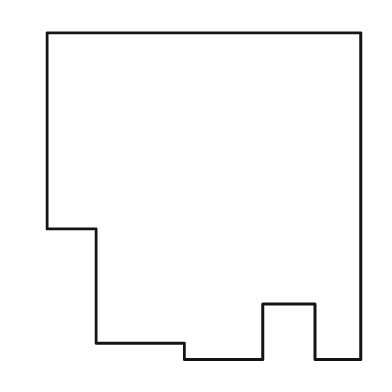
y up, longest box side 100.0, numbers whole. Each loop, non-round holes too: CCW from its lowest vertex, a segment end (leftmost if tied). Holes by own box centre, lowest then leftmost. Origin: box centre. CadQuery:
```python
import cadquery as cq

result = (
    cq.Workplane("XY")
    .moveTo(-6.0, -50.0)
    .lineTo(18.0, -50.0)
    .lineTo(18.0, -33.0)
    .lineTo(34.0, -33.0)
    .lineTo(34.0, -50.0)
    .lineTo(48.0, -50.0)
    .lineTo(48.0, 50.0)
    .lineTo(-48.0, 50.0)
    .lineTo(-48.0, -10.0)
    .lineTo(-33.0, -10.0)
    .lineTo(-33.0, -45.0)
    .lineTo(-6.0, -45.0)
    .close()
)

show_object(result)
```